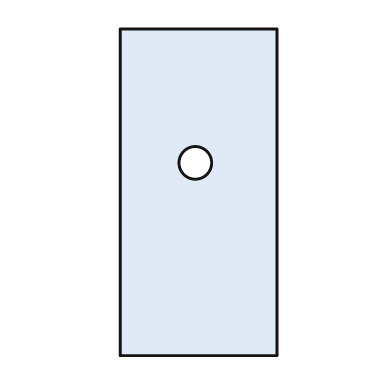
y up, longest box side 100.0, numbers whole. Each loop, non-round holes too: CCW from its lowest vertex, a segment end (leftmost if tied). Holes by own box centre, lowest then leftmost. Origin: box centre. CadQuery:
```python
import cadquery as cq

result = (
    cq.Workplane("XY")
    .moveTo(-24.0, -50.0)
    .lineTo(24.0, -50.0)
    .lineTo(24.0, 50.0)
    .lineTo(-24.0, 50.0)
    .close()
    .moveTo(-1.0, 9.0)
    .circle(5.0)
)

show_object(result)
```